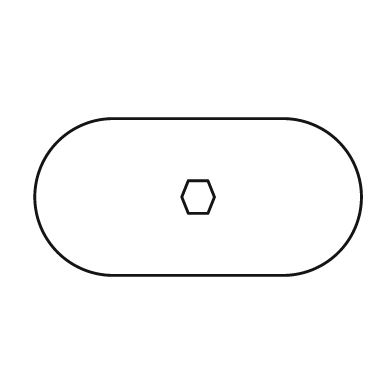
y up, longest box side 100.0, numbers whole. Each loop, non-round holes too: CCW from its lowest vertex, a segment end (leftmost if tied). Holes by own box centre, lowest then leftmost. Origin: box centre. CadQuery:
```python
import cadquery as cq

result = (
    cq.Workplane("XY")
    .moveTo(-26.0, -24.0)
    .lineTo(26.0, -24.0)
    .threePointArc((50.0, 0.0), (26.0, 24.0))
    .lineTo(-26.0, 24.0)
    .threePointArc((-50.0, 0.0), (-26.0, -24.0))
    .close()
    .moveTo(-3.0, -5.0)
    .lineTo(3.0, -5.0)
    .lineTo(5.0, 0.0)
    .lineTo(3.0, 5.0)
    .lineTo(-3.0, 5.0)
    .lineTo(-5.0, 0.0)
    .close()
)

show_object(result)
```